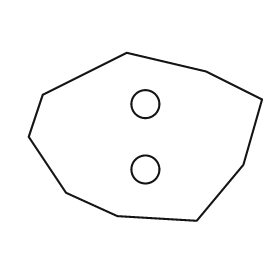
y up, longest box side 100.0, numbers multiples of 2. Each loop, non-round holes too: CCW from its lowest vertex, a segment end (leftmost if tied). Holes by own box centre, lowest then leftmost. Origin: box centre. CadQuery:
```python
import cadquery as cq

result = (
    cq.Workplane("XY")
    .moveTo(22.0, -36.0)
    .lineTo(42.0, -12.0)
    .lineTo(50.0, 16.0)
    .lineTo(26.0, 28.0)
    .lineTo(-8.0, 36.0)
    .lineTo(-44.0, 18.0)
    .lineTo(-50.0, 0.0)
    .lineTo(-34.0, -24.0)
    .lineTo(-12.0, -34.0)
    .close()
    .moveTo(0.0, -14.0)
    .circle(6.0)
    .moveTo(0.0, 14.0)
    .circle(6.0)
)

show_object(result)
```